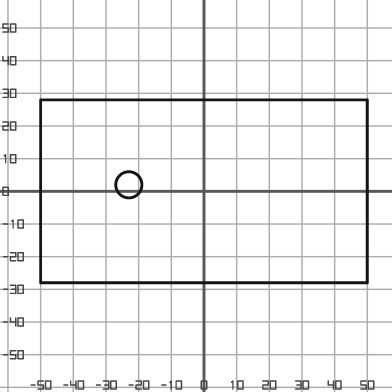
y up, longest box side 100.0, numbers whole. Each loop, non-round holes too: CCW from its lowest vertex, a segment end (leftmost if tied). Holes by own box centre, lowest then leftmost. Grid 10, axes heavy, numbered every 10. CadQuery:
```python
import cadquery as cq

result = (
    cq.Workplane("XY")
    .moveTo(-50.0, -28.0)
    .lineTo(50.0, -28.0)
    .lineTo(50.0, 28.0)
    .lineTo(-50.0, 28.0)
    .close()
    .moveTo(-23.0, 2.0)
    .circle(4.0)
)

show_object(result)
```